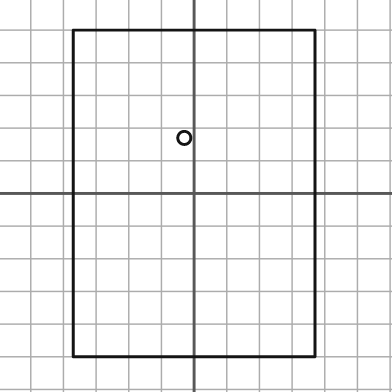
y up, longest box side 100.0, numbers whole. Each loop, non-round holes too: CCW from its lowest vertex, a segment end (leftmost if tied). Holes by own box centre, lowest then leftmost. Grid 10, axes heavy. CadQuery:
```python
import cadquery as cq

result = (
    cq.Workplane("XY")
    .moveTo(-37.0, -50.0)
    .lineTo(37.0, -50.0)
    .lineTo(37.0, 50.0)
    .lineTo(-37.0, 50.0)
    .close()
    .moveTo(-3.0, 17.0)
    .circle(2.0)
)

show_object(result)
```